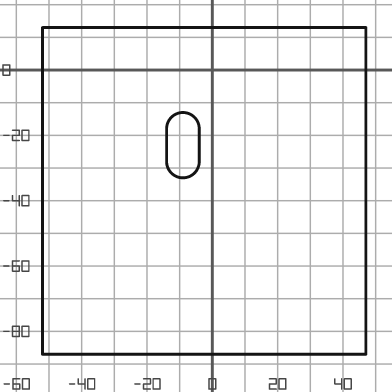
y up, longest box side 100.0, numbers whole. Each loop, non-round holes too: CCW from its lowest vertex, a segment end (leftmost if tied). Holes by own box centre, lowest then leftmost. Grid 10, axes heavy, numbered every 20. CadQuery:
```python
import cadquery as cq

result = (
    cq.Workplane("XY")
    .moveTo(-52.0, -87.0)
    .lineTo(47.0, -87.0)
    .lineTo(47.0, 13.0)
    .lineTo(-52.0, 13.0)
    .close()
    .moveTo(-14.0, -28.0)
    .threePointArc((-9.0, -33.0), (-4.0, -28.0))
    .lineTo(-4.0, -18.0)
    .threePointArc((-9.0, -13.0), (-14.0, -18.0))
    .close()
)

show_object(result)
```